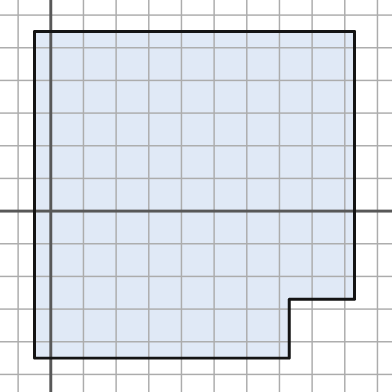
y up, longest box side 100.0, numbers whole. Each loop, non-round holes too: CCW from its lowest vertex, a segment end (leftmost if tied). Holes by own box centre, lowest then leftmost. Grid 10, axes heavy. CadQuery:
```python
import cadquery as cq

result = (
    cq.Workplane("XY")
    .moveTo(-5.0, -45.0)
    .lineTo(73.0, -45.0)
    .lineTo(73.0, -27.0)
    .lineTo(93.0, -27.0)
    .lineTo(93.0, 55.0)
    .lineTo(-5.0, 55.0)
    .close()
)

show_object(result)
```